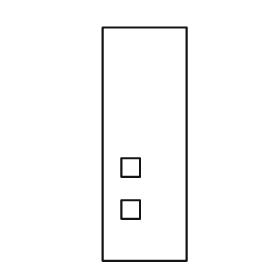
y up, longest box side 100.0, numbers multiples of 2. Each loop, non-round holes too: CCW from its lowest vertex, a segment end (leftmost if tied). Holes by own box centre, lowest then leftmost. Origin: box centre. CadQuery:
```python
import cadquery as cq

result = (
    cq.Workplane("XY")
    .moveTo(-18.0, -50.0)
    .lineTo(18.0, -50.0)
    .lineTo(18.0, 50.0)
    .lineTo(-18.0, 50.0)
    .close()
    .moveTo(-10.0, -32.0)
    .lineTo(-2.0, -32.0)
    .lineTo(-2.0, -24.0)
    .lineTo(-10.0, -24.0)
    .close()
    .moveTo(-10.0, -14.0)
    .lineTo(-2.0, -14.0)
    .lineTo(-2.0, -6.0)
    .lineTo(-10.0, -6.0)
    .close()
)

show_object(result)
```